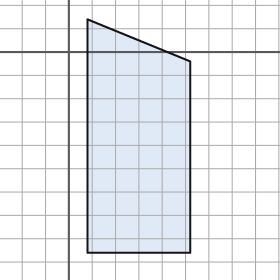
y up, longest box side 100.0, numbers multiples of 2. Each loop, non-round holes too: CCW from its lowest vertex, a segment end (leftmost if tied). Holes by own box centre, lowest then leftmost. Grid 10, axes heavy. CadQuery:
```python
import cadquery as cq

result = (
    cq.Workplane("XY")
    .moveTo(8.0, -86.0)
    .lineTo(52.0, -86.0)
    .lineTo(52.0, -4.0)
    .lineTo(8.0, 14.0)
    .close()
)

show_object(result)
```